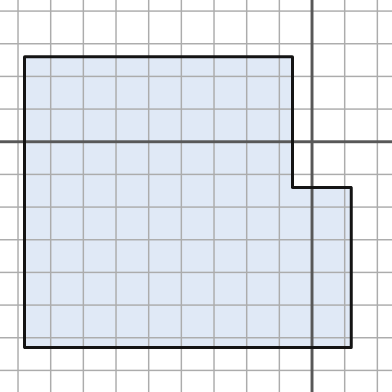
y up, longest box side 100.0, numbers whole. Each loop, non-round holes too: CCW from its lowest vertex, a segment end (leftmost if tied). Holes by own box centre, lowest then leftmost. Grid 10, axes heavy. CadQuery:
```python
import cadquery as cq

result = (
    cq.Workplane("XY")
    .moveTo(-88.0, -63.0)
    .lineTo(12.0, -63.0)
    .lineTo(12.0, -14.0)
    .lineTo(-6.0, -14.0)
    .lineTo(-6.0, 26.0)
    .lineTo(-88.0, 26.0)
    .close()
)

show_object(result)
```